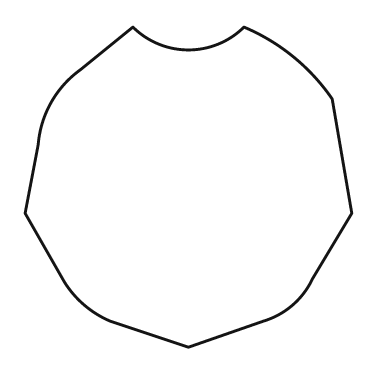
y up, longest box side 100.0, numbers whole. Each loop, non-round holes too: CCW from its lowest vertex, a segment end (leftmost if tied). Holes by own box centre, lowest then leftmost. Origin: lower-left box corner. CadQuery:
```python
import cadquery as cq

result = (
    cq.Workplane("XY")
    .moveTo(50.0, 0.0)
    .lineTo(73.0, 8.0)
    .threePointArc((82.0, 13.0), (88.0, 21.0))
    .lineTo(100.0, 41.0)
    .lineTo(94.0, 76.0)
    .threePointArc((82.0, 89.0), (67.0, 98.0))
    .threePointArc((50.0, 91.0), (33.0, 98.0))
    .lineTo(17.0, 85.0)
    .threePointArc((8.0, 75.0), (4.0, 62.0))
    .lineTo(0.0, 41.0)
    .lineTo(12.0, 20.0)
    .threePointArc((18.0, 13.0), (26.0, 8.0))
    .close()
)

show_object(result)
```